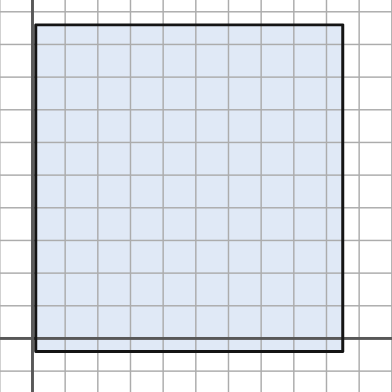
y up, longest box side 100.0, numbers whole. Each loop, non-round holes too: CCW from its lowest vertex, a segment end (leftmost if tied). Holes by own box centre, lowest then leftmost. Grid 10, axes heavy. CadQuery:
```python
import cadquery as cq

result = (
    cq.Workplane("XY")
    .moveTo(1.0, -4.0)
    .lineTo(95.0, -4.0)
    .lineTo(95.0, 96.0)
    .lineTo(1.0, 96.0)
    .close()
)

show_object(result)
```